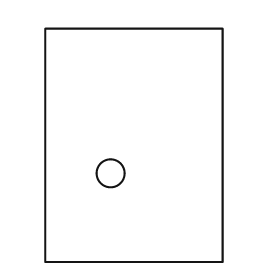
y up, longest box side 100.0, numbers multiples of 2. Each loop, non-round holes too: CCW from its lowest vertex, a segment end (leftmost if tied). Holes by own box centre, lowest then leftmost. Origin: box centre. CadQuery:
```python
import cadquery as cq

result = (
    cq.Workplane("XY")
    .moveTo(-38.0, -50.0)
    .lineTo(38.0, -50.0)
    .lineTo(38.0, 50.0)
    .lineTo(-38.0, 50.0)
    .close()
    .moveTo(-10.0, -12.0)
    .circle(6.0)
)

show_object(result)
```